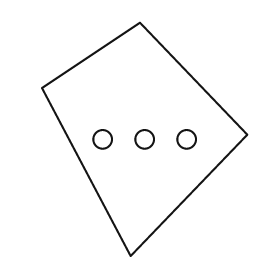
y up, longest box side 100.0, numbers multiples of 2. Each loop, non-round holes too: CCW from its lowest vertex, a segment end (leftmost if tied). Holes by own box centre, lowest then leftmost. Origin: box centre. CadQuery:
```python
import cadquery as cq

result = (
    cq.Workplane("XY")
    .moveTo(-6.0, -50.0)
    .lineTo(44.0, 2.0)
    .lineTo(-2.0, 50.0)
    .lineTo(-44.0, 22.0)
    .close()
    .moveTo(-18.0, 0.0)
    .circle(4.0)
    .moveTo(0.0, 0.0)
    .circle(4.0)
    .moveTo(18.0, 0.0)
    .circle(4.0)
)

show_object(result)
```